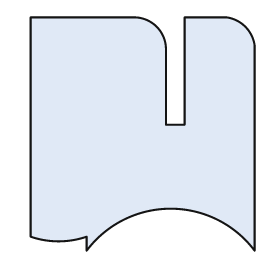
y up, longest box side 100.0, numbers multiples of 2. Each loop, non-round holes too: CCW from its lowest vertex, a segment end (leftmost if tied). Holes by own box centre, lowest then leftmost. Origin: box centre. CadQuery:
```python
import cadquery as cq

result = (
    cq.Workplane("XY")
    .moveTo(-24.0, -50.0)
    .threePointArc((12.0, -32.0), (48.0, -50.0))
    .lineTo(48.0, 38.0)
    .threePointArc((44.0, 46.0), (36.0, 50.0))
    .lineTo(18.0, 50.0)
    .lineTo(18.0, 4.0)
    .lineTo(10.0, 4.0)
    .lineTo(10.0, 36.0)
    .threePointArc((6.0, 46.0), (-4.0, 50.0))
    .lineTo(-48.0, 50.0)
    .lineTo(-48.0, -44.0)
    .threePointArc((-36.0, -46.0), (-24.0, -44.0))
    .close()
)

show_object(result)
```